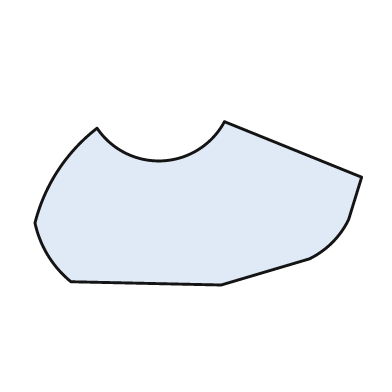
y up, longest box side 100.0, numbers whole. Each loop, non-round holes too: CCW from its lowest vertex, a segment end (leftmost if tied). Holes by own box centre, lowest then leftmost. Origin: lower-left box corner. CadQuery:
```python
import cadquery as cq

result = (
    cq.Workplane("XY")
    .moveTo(57.0, 0.0)
    .lineTo(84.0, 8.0)
    .threePointArc((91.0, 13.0), (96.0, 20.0))
    .lineTo(100.0, 33.0)
    .lineTo(58.0, 50.0)
    .threePointArc((39.0, 38.0), (19.0, 48.0))
    .threePointArc((7.0, 35.0), (0.0, 19.0))
    .threePointArc((4.0, 9.0), (11.0, 1.0))
    .close()
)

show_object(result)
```